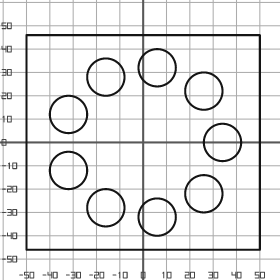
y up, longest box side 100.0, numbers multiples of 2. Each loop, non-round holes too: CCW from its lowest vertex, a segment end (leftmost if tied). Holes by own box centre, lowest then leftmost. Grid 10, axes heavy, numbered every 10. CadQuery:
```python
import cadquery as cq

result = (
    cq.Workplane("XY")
    .moveTo(-50.0, -46.0)
    .lineTo(50.0, -46.0)
    .lineTo(50.0, 46.0)
    .lineTo(-50.0, 46.0)
    .close()
    .moveTo(6.0, -32.0)
    .circle(8.0)
    .moveTo(-16.0, -28.0)
    .circle(8.0)
    .moveTo(26.0, -22.0)
    .circle(8.0)
    .moveTo(-32.0, -12.0)
    .circle(8.0)
    .moveTo(34.0, 0.0)
    .circle(8.0)
    .moveTo(-32.0, 12.0)
    .circle(8.0)
    .moveTo(26.0, 22.0)
    .circle(8.0)
    .moveTo(-16.0, 28.0)
    .circle(8.0)
    .moveTo(6.0, 32.0)
    .circle(8.0)
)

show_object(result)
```